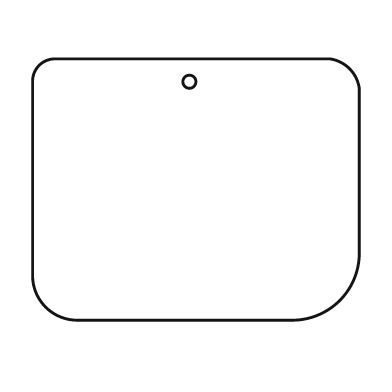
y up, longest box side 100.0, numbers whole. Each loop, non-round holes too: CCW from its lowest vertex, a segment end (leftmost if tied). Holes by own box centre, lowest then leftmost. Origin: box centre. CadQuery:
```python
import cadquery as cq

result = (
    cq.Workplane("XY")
    .moveTo(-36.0, -40.0)
    .lineTo(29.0, -40.0)
    .threePointArc((44.0, -34.0), (50.0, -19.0))
    .lineTo(50.0, 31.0)
    .threePointArc((47.0, 37.0), (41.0, 40.0))
    .lineTo(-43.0, 40.0)
    .threePointArc((-48.0, 38.0), (-50.0, 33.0))
    .lineTo(-50.0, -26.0)
    .threePointArc((-46.0, -36.0), (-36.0, -40.0))
    .close()
    .moveTo(-2.0, 33.0)
    .circle(2.0)
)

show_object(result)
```